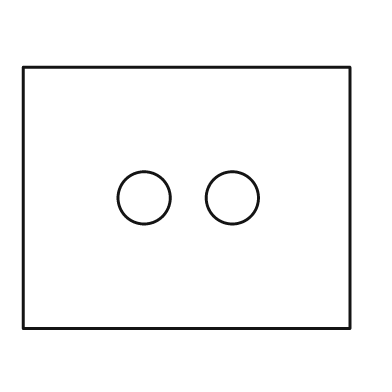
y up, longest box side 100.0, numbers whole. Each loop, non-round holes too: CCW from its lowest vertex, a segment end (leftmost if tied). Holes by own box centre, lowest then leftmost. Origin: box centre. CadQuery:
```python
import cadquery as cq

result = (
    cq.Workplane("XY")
    .moveTo(-50.0, -40.0)
    .lineTo(50.0, -40.0)
    .lineTo(50.0, 40.0)
    .lineTo(-50.0, 40.0)
    .close()
    .moveTo(-13.0, 0.0)
    .circle(8.0)
    .moveTo(14.0, 0.0)
    .circle(8.0)
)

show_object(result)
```